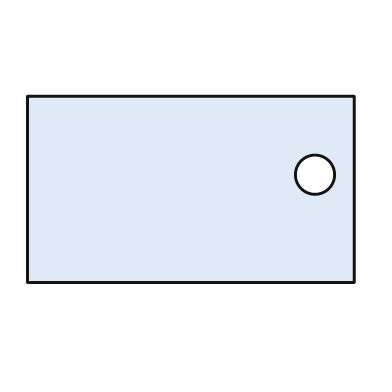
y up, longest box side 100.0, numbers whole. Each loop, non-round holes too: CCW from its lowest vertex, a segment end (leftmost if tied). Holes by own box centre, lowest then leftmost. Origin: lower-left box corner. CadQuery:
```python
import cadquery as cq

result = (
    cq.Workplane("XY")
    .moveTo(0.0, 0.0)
    .lineTo(100.0, 0.0)
    .lineTo(100.0, 57.0)
    .lineTo(0.0, 57.0)
    .close()
    .moveTo(88.0, 33.0)
    .circle(6.0)
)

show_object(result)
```